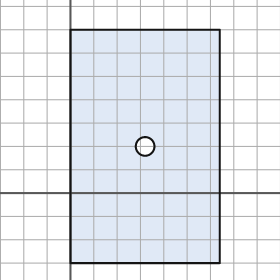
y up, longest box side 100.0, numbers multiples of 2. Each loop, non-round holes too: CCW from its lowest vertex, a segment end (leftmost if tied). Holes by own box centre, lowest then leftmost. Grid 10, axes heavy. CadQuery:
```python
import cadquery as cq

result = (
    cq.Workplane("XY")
    .moveTo(0.0, -30.0)
    .lineTo(64.0, -30.0)
    .lineTo(64.0, 70.0)
    .lineTo(0.0, 70.0)
    .close()
    .moveTo(32.0, 20.0)
    .circle(4.0)
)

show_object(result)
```